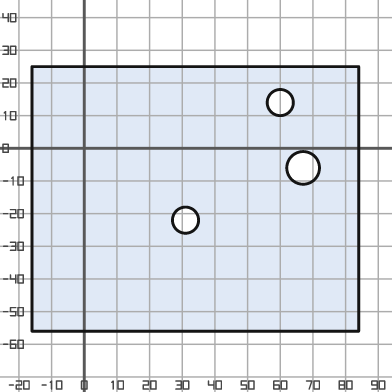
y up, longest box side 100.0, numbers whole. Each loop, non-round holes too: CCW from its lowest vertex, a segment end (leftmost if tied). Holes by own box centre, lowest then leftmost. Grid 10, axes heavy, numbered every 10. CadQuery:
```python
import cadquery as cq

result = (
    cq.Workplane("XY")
    .moveTo(-16.0, -56.0)
    .lineTo(84.0, -56.0)
    .lineTo(84.0, 25.0)
    .lineTo(-16.0, 25.0)
    .close()
    .moveTo(31.0, -22.0)
    .circle(4.0)
    .moveTo(67.0, -6.0)
    .circle(5.0)
    .moveTo(60.0, 14.0)
    .circle(4.0)
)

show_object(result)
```